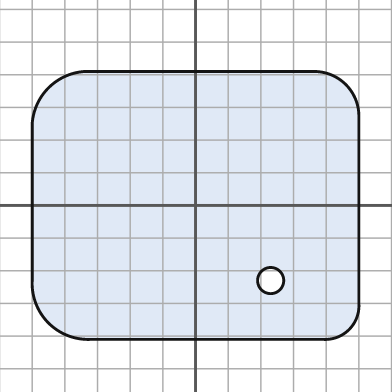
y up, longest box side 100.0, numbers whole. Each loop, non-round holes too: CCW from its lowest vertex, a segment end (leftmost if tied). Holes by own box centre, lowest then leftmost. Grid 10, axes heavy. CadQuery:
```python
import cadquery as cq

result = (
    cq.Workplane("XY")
    .moveTo(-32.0, -41.0)
    .lineTo(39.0, -41.0)
    .threePointArc((47.0, -38.0), (50.0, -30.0))
    .lineTo(50.0, 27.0)
    .threePointArc((46.0, 37.0), (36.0, 41.0))
    .lineTo(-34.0, 41.0)
    .threePointArc((-45.0, 36.0), (-50.0, 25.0))
    .lineTo(-50.0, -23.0)
    .threePointArc((-45.0, -36.0), (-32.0, -41.0))
    .close()
    .moveTo(23.0, -23.0)
    .circle(4.0)
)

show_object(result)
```